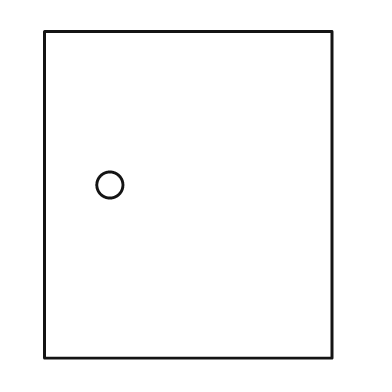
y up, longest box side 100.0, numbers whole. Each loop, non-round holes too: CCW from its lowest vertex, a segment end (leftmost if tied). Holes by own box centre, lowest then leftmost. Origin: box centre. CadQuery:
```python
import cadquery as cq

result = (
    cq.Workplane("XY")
    .moveTo(-44.0, -50.0)
    .lineTo(44.0, -50.0)
    .lineTo(44.0, 50.0)
    .lineTo(-44.0, 50.0)
    .close()
    .moveTo(-24.0, 3.0)
    .circle(4.0)
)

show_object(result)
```